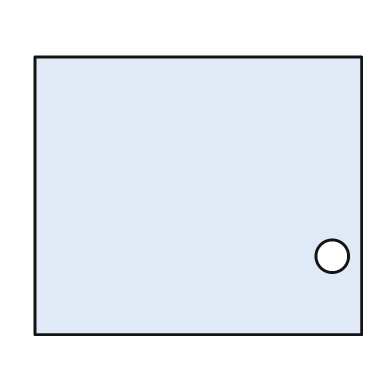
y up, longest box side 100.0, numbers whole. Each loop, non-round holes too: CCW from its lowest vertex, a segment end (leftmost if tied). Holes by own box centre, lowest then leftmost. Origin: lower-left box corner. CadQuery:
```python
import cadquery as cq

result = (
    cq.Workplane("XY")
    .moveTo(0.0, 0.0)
    .lineTo(100.0, 0.0)
    .lineTo(100.0, 85.0)
    .lineTo(0.0, 85.0)
    .close()
    .moveTo(91.0, 24.0)
    .circle(5.0)
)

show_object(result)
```